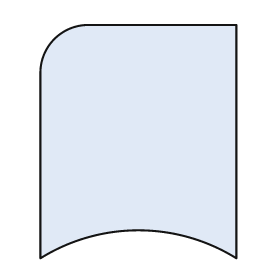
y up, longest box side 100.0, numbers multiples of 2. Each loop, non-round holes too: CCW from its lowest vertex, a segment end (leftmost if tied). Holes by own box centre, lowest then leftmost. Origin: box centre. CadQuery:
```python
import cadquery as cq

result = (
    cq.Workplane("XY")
    .moveTo(-42.0, -50.0)
    .threePointArc((0.0, -38.0), (42.0, -50.0))
    .lineTo(42.0, 50.0)
    .lineTo(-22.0, 50.0)
    .threePointArc((-36.0, 44.0), (-42.0, 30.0))
    .close()
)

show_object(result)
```